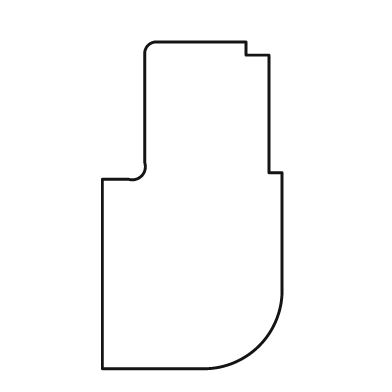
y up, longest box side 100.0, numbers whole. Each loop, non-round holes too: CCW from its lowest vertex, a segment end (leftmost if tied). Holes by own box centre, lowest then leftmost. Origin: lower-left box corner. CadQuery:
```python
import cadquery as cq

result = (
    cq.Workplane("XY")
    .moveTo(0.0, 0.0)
    .lineTo(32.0, 0.0)
    .threePointArc((48.0, 7.0), (55.0, 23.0))
    .lineTo(55.0, 60.0)
    .lineTo(51.0, 60.0)
    .lineTo(51.0, 96.0)
    .lineTo(44.0, 96.0)
    .lineTo(44.0, 100.0)
    .lineTo(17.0, 100.0)
    .threePointArc((14.0, 99.0), (13.0, 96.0))
    .lineTo(13.0, 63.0)
    .threePointArc((12.0, 59.0), (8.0, 58.0))
    .lineTo(0.0, 58.0)
    .close()
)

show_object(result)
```